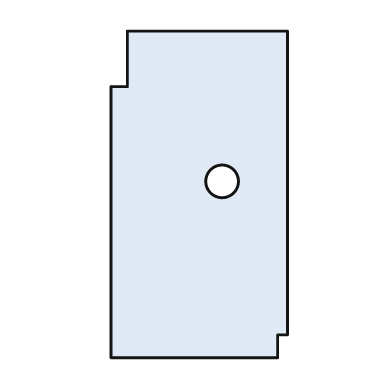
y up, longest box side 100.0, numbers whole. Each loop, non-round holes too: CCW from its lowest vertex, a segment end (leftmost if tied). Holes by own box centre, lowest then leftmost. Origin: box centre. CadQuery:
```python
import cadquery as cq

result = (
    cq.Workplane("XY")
    .moveTo(-27.0, -50.0)
    .lineTo(24.0, -50.0)
    .lineTo(24.0, -43.0)
    .lineTo(27.0, -43.0)
    .lineTo(27.0, 50.0)
    .lineTo(-22.0, 50.0)
    .lineTo(-22.0, 33.0)
    .lineTo(-27.0, 33.0)
    .close()
    .moveTo(7.0, 4.0)
    .circle(5.0)
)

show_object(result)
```